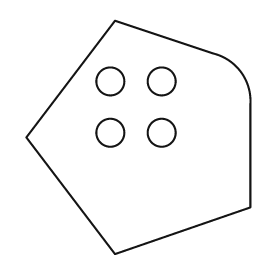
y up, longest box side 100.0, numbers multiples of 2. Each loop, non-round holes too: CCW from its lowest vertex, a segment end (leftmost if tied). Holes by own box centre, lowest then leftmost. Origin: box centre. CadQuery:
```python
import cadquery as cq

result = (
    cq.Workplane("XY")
    .moveTo(-10.0, -50.0)
    .lineTo(48.0, -30.0)
    .lineTo(48.0, 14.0)
    .threePointArc((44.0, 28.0), (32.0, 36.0))
    .lineTo(-10.0, 50.0)
    .lineTo(-48.0, 0.0)
    .close()
    .moveTo(-12.0, 2.0)
    .circle(6.0)
    .moveTo(10.0, 2.0)
    .circle(6.0)
    .moveTo(-12.0, 24.0)
    .circle(6.0)
    .moveTo(10.0, 24.0)
    .circle(6.0)
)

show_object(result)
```